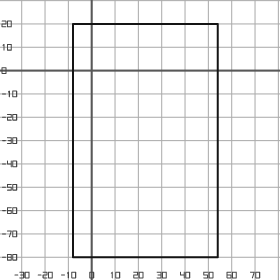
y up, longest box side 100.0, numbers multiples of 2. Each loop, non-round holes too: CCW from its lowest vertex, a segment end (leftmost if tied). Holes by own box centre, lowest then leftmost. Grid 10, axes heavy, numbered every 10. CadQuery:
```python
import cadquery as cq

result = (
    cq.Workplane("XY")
    .moveTo(-8.0, -80.0)
    .lineTo(54.0, -80.0)
    .lineTo(54.0, 20.0)
    .lineTo(-8.0, 20.0)
    .close()
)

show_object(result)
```